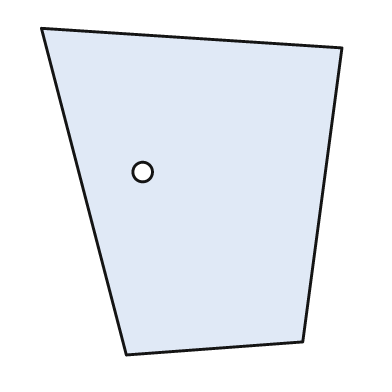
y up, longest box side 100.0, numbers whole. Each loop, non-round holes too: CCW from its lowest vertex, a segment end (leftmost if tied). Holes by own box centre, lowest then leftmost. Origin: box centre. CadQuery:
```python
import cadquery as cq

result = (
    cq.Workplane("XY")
    .moveTo(-20.0, -50.0)
    .lineTo(34.0, -46.0)
    .lineTo(46.0, 44.0)
    .lineTo(-46.0, 50.0)
    .close()
    .moveTo(-15.0, 6.0)
    .circle(3.0)
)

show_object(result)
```